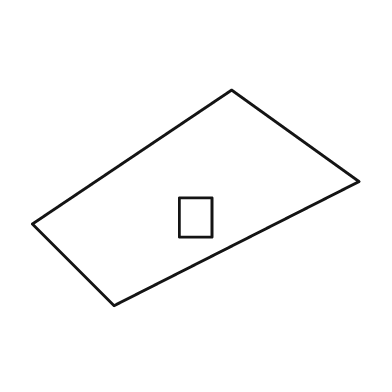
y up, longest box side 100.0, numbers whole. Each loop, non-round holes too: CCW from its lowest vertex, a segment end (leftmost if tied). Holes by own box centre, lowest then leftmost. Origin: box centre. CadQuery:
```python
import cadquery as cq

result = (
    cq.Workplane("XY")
    .moveTo(-25.0, -33.0)
    .lineTo(50.0, 5.0)
    .lineTo(11.0, 33.0)
    .lineTo(-50.0, -8.0)
    .close()
    .moveTo(-5.0, -12.0)
    .lineTo(5.0, -12.0)
    .lineTo(5.0, 0.0)
    .lineTo(-5.0, 0.0)
    .close()
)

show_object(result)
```